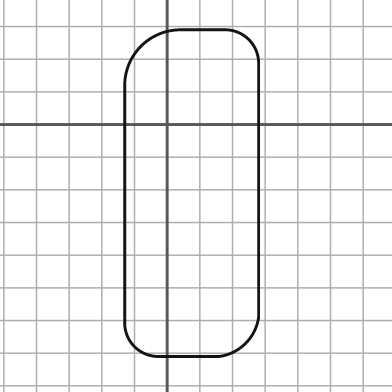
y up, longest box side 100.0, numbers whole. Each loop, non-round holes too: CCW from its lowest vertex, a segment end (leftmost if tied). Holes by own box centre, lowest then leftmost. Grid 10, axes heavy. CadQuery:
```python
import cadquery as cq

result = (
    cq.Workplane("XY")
    .moveTo(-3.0, -71.0)
    .lineTo(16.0, -71.0)
    .threePointArc((24.0, -67.0), (28.0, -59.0))
    .lineTo(28.0, 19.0)
    .threePointArc((25.0, 26.0), (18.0, 29.0))
    .lineTo(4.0, 29.0)
    .threePointArc((-8.0, 24.0), (-13.0, 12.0))
    .lineTo(-13.0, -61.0)
    .threePointArc((-10.0, -68.0), (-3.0, -71.0))
    .close()
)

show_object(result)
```